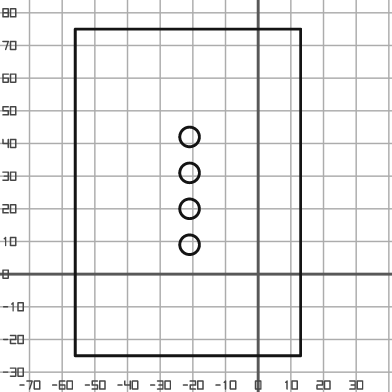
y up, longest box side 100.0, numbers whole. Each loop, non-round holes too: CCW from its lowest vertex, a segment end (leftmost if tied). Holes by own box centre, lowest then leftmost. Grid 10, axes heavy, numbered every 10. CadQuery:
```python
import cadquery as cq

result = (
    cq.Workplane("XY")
    .moveTo(-56.0, -25.0)
    .lineTo(13.0, -25.0)
    .lineTo(13.0, 75.0)
    .lineTo(-56.0, 75.0)
    .close()
    .moveTo(-21.0, 9.0)
    .circle(3.0)
    .moveTo(-21.0, 20.0)
    .circle(3.0)
    .moveTo(-21.0, 31.0)
    .circle(3.0)
    .moveTo(-21.0, 42.0)
    .circle(3.0)
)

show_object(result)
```